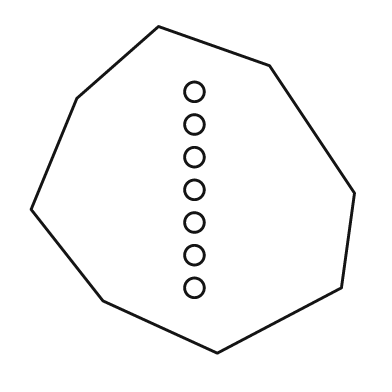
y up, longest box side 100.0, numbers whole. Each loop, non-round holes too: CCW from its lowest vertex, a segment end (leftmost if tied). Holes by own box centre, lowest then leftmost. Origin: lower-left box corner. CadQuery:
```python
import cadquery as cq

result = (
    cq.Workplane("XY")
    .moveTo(57.0, 0.0)
    .lineTo(95.0, 20.0)
    .lineTo(99.0, 49.0)
    .lineTo(73.0, 88.0)
    .lineTo(39.0, 100.0)
    .lineTo(14.0, 78.0)
    .lineTo(0.0, 44.0)
    .lineTo(22.0, 16.0)
    .close()
    .moveTo(50.0, 20.0)
    .circle(3.0)
    .moveTo(50.0, 30.0)
    .circle(3.0)
    .moveTo(50.0, 40.0)
    .circle(3.0)
    .moveTo(50.0, 50.0)
    .circle(3.0)
    .moveTo(50.0, 60.0)
    .circle(3.0)
    .moveTo(50.0, 70.0)
    .circle(3.0)
    .moveTo(50.0, 80.0)
    .circle(3.0)
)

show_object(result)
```